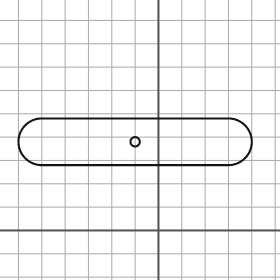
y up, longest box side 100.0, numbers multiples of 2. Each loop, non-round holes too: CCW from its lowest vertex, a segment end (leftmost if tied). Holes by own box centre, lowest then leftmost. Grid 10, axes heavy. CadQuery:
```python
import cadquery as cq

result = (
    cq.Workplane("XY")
    .moveTo(-50.0, 28.0)
    .lineTo(30.0, 28.0)
    .threePointArc((40.0, 38.0), (30.0, 48.0))
    .lineTo(-50.0, 48.0)
    .threePointArc((-60.0, 38.0), (-50.0, 28.0))
    .close()
    .moveTo(-10.0, 38.0)
    .circle(2.0)
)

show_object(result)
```